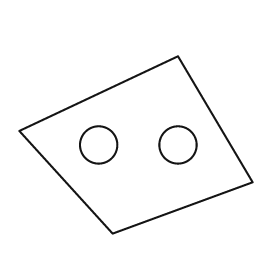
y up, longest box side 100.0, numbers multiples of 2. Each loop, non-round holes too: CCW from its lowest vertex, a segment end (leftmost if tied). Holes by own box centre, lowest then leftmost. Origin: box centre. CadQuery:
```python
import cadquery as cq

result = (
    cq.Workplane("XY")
    .moveTo(-10.0, -38.0)
    .lineTo(50.0, -16.0)
    .lineTo(18.0, 38.0)
    .lineTo(-50.0, 6.0)
    .close()
    .moveTo(-16.0, 0.0)
    .circle(8.0)
    .moveTo(18.0, 0.0)
    .circle(8.0)
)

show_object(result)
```